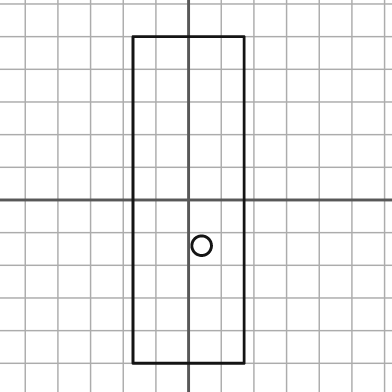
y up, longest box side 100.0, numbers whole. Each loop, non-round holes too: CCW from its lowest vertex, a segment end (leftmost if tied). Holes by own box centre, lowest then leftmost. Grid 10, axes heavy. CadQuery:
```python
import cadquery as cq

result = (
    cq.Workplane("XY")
    .moveTo(-17.0, -50.0)
    .lineTo(17.0, -50.0)
    .lineTo(17.0, 50.0)
    .lineTo(-17.0, 50.0)
    .close()
    .moveTo(4.0, -14.0)
    .circle(3.0)
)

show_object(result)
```